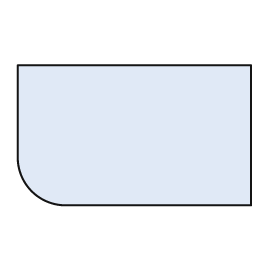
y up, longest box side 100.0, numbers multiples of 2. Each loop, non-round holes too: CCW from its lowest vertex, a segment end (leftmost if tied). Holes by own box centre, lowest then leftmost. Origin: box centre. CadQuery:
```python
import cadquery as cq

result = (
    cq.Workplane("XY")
    .moveTo(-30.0, -30.0)
    .lineTo(50.0, -30.0)
    .lineTo(50.0, 30.0)
    .lineTo(-50.0, 30.0)
    .lineTo(-50.0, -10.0)
    .threePointArc((-44.0, -24.0), (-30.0, -30.0))
    .close()
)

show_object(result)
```